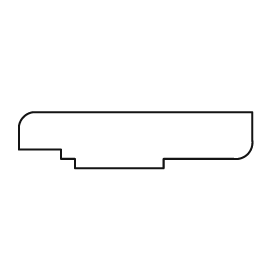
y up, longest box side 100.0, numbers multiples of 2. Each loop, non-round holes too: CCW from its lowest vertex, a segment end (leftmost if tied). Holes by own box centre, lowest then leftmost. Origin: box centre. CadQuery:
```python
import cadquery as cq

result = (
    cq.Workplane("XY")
    .moveTo(-26.0, -12.0)
    .lineTo(12.0, -12.0)
    .lineTo(12.0, -8.0)
    .lineTo(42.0, -8.0)
    .threePointArc((48.0, -6.0), (50.0, 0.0))
    .lineTo(50.0, 12.0)
    .lineTo(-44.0, 12.0)
    .threePointArc((-48.0, 10.0), (-50.0, 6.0))
    .lineTo(-50.0, -4.0)
    .lineTo(-32.0, -4.0)
    .lineTo(-32.0, -8.0)
    .lineTo(-26.0, -8.0)
    .close()
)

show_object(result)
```